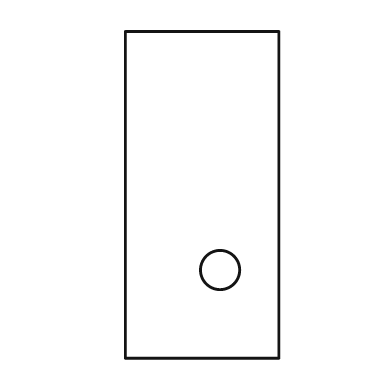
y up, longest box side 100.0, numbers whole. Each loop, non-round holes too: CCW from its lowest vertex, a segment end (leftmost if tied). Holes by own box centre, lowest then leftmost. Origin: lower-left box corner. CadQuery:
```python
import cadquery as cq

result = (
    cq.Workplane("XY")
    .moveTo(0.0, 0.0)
    .lineTo(47.0, 0.0)
    .lineTo(47.0, 100.0)
    .lineTo(0.0, 100.0)
    .close()
    .moveTo(29.0, 27.0)
    .circle(6.0)
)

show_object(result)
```